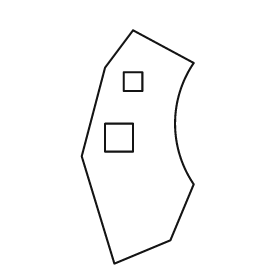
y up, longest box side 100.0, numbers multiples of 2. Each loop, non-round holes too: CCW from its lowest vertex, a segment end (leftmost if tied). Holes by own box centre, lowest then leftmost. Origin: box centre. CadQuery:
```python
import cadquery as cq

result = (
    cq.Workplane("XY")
    .moveTo(-10.0, -50.0)
    .lineTo(14.0, -40.0)
    .lineTo(24.0, -16.0)
    .threePointArc((16.0, 10.0), (24.0, 36.0))
    .lineTo(-2.0, 50.0)
    .lineTo(-14.0, 34.0)
    .lineTo(-24.0, -4.0)
    .close()
    .moveTo(-14.0, -2.0)
    .lineTo(-2.0, -2.0)
    .lineTo(-2.0, 10.0)
    .lineTo(-14.0, 10.0)
    .close()
    .moveTo(-6.0, 24.0)
    .lineTo(2.0, 24.0)
    .lineTo(2.0, 32.0)
    .lineTo(-6.0, 32.0)
    .close()
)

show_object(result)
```